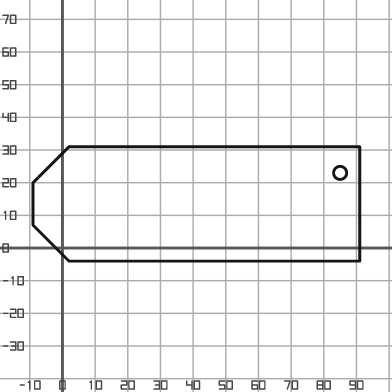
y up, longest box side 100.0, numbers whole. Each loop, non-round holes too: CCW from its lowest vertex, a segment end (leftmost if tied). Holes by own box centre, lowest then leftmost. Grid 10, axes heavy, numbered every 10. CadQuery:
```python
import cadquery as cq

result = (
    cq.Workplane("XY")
    .moveTo(2.0, -4.0)
    .lineTo(91.0, -4.0)
    .lineTo(91.0, 31.0)
    .lineTo(2.0, 31.0)
    .lineTo(-9.0, 20.0)
    .lineTo(-9.0, 7.0)
    .close()
    .moveTo(85.0, 23.0)
    .circle(2.0)
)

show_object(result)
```